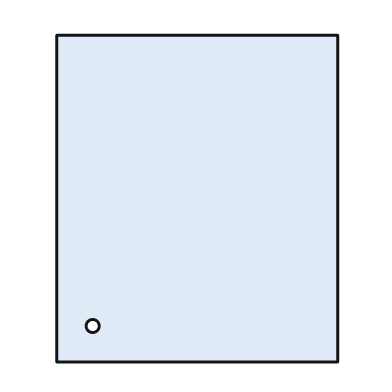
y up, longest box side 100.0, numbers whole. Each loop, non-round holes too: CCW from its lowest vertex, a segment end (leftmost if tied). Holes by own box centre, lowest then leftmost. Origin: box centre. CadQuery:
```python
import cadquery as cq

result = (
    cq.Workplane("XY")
    .moveTo(-43.0, -50.0)
    .lineTo(43.0, -50.0)
    .lineTo(43.0, 50.0)
    .lineTo(-43.0, 50.0)
    .close()
    .moveTo(-32.0, -39.0)
    .circle(2.0)
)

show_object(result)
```